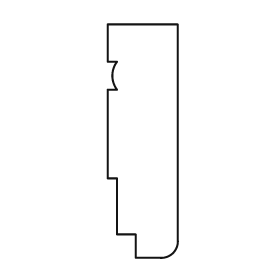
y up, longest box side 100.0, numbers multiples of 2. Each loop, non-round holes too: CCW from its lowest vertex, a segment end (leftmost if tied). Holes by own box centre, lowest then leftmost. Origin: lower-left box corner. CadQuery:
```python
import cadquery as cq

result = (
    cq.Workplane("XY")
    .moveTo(12.0, 0.0)
    .lineTo(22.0, 0.0)
    .threePointArc((28.0, 2.0), (30.0, 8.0))
    .lineTo(30.0, 100.0)
    .lineTo(0.0, 100.0)
    .lineTo(0.0, 84.0)
    .lineTo(4.0, 84.0)
    .threePointArc((2.0, 78.0), (4.0, 72.0))
    .lineTo(0.0, 72.0)
    .lineTo(0.0, 34.0)
    .lineTo(4.0, 34.0)
    .lineTo(4.0, 10.0)
    .lineTo(12.0, 10.0)
    .close()
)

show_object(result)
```